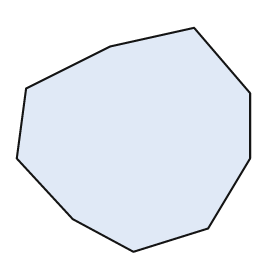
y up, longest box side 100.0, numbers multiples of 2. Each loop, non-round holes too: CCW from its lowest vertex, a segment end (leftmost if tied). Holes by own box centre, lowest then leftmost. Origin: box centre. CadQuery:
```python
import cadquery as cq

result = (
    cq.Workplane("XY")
    .moveTo(0.0, -48.0)
    .lineTo(32.0, -38.0)
    .lineTo(50.0, -8.0)
    .lineTo(50.0, 20.0)
    .lineTo(26.0, 48.0)
    .lineTo(-10.0, 40.0)
    .lineTo(-46.0, 22.0)
    .lineTo(-50.0, -8.0)
    .lineTo(-26.0, -34.0)
    .close()
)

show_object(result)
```